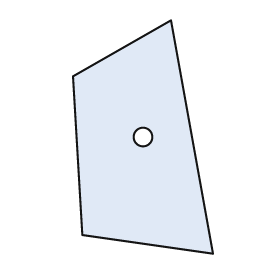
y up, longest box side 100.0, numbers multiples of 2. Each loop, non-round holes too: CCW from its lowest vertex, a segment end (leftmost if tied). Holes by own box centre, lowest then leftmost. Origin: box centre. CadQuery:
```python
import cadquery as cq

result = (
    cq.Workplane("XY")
    .moveTo(30.0, -50.0)
    .lineTo(12.0, 50.0)
    .lineTo(-30.0, 26.0)
    .lineTo(-26.0, -42.0)
    .close()
    .moveTo(0.0, 0.0)
    .circle(4.0)
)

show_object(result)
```